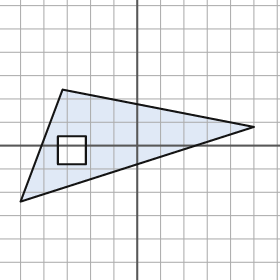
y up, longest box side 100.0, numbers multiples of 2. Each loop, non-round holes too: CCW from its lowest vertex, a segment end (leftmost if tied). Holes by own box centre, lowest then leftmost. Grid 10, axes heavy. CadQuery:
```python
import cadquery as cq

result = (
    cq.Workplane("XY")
    .moveTo(-50.0, -24.0)
    .lineTo(50.0, 8.0)
    .lineTo(-32.0, 24.0)
    .close()
    .moveTo(-34.0, -8.0)
    .lineTo(-22.0, -8.0)
    .lineTo(-22.0, 4.0)
    .lineTo(-34.0, 4.0)
    .close()
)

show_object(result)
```